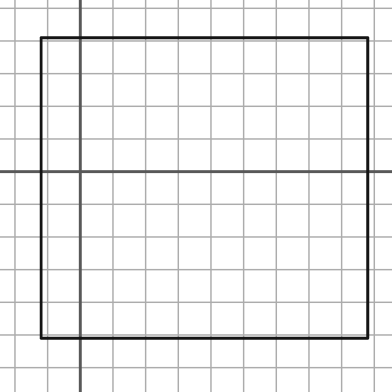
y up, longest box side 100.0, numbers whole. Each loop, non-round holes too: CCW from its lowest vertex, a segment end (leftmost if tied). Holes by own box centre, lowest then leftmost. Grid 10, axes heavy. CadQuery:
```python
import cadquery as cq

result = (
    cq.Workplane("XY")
    .moveTo(-12.0, -51.0)
    .lineTo(88.0, -51.0)
    .lineTo(88.0, 41.0)
    .lineTo(-12.0, 41.0)
    .close()
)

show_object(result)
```